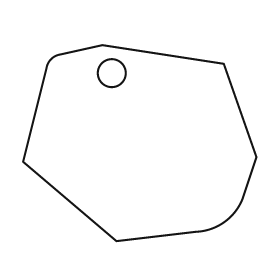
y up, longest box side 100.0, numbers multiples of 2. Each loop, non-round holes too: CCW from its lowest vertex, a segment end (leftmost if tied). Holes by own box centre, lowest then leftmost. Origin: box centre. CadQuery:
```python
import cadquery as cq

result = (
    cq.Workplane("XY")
    .moveTo(-10.0, -42.0)
    .lineTo(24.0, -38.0)
    .threePointArc((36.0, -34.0), (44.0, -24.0))
    .lineTo(50.0, -6.0)
    .lineTo(36.0, 34.0)
    .lineTo(-16.0, 42.0)
    .lineTo(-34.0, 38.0)
    .threePointArc((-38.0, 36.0), (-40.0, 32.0))
    .lineTo(-50.0, -8.0)
    .close()
    .moveTo(-12.0, 30.0)
    .circle(6.0)
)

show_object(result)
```